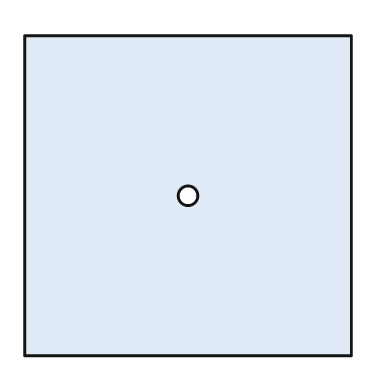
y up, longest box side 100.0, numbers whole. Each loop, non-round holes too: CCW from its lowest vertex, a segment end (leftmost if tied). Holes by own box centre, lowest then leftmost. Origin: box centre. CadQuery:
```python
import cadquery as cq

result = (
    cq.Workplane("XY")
    .moveTo(-50.0, -49.0)
    .lineTo(50.0, -49.0)
    .lineTo(50.0, 49.0)
    .lineTo(-50.0, 49.0)
    .close()
    .moveTo(0.0, 0.0)
    .circle(3.0)
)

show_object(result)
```